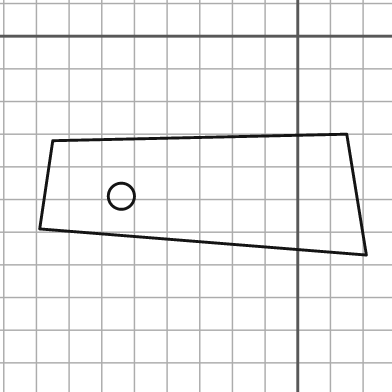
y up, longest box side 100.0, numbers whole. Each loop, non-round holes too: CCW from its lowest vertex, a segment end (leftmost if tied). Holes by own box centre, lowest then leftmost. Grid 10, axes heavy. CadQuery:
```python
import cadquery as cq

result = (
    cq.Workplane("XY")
    .moveTo(21.0, -67.0)
    .lineTo(15.0, -30.0)
    .lineTo(-75.0, -32.0)
    .lineTo(-79.0, -59.0)
    .close()
    .moveTo(-54.0, -49.0)
    .circle(4.0)
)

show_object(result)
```